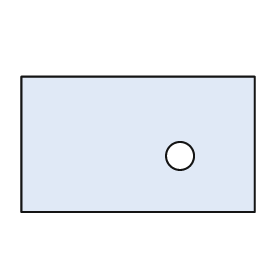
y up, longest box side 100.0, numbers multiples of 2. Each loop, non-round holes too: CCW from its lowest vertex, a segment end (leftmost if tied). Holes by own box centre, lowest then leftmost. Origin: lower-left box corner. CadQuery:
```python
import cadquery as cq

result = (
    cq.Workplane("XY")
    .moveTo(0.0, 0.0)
    .lineTo(100.0, 0.0)
    .lineTo(100.0, 58.0)
    .lineTo(0.0, 58.0)
    .close()
    .moveTo(68.0, 24.0)
    .circle(6.0)
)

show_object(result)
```